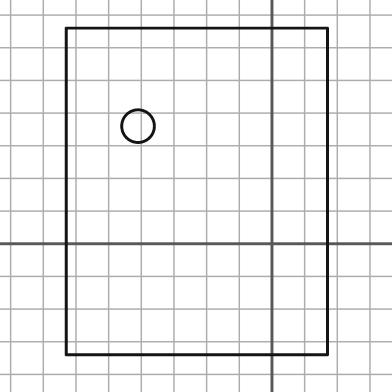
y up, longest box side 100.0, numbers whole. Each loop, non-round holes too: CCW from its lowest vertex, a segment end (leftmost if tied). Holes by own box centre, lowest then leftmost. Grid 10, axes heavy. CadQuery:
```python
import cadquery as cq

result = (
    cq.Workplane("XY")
    .moveTo(-63.0, -34.0)
    .lineTo(17.0, -34.0)
    .lineTo(17.0, 66.0)
    .lineTo(-63.0, 66.0)
    .close()
    .moveTo(-41.0, 36.0)
    .circle(5.0)
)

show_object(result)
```